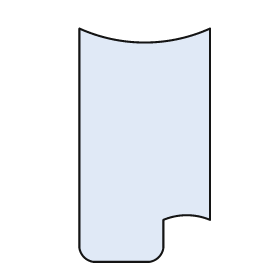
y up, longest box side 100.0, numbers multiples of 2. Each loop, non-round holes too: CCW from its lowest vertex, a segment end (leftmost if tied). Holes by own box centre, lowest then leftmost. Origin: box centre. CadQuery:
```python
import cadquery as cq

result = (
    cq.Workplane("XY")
    .moveTo(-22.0, -50.0)
    .lineTo(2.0, -50.0)
    .threePointArc((6.0, -48.0), (8.0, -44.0))
    .lineTo(8.0, -32.0)
    .threePointArc((18.0, -30.0), (28.0, -32.0))
    .lineTo(28.0, 50.0)
    .threePointArc((0.0, 44.0), (-28.0, 50.0))
    .lineTo(-28.0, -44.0)
    .threePointArc((-26.0, -48.0), (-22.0, -50.0))
    .close()
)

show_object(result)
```